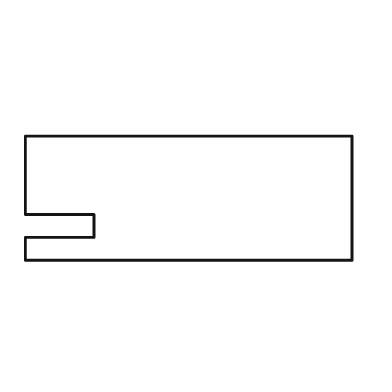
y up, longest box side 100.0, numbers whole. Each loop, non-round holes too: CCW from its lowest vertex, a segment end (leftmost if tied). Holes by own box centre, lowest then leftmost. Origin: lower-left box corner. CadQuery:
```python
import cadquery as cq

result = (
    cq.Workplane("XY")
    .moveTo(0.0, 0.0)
    .lineTo(100.0, 0.0)
    .lineTo(100.0, 38.0)
    .lineTo(0.0, 38.0)
    .lineTo(0.0, 14.0)
    .lineTo(21.0, 14.0)
    .lineTo(21.0, 7.0)
    .lineTo(0.0, 7.0)
    .close()
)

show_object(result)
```